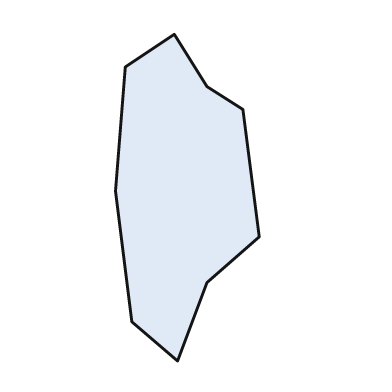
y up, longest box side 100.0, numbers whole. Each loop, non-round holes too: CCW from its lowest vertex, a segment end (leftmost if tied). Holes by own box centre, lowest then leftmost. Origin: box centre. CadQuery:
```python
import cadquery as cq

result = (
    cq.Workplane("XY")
    .moveTo(-3.0, -50.0)
    .lineTo(6.0, -26.0)
    .lineTo(22.0, -12.0)
    .lineTo(17.0, 27.0)
    .lineTo(6.0, 34.0)
    .lineTo(-4.0, 50.0)
    .lineTo(-19.0, 40.0)
    .lineTo(-22.0, 2.0)
    .lineTo(-17.0, -38.0)
    .close()
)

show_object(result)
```